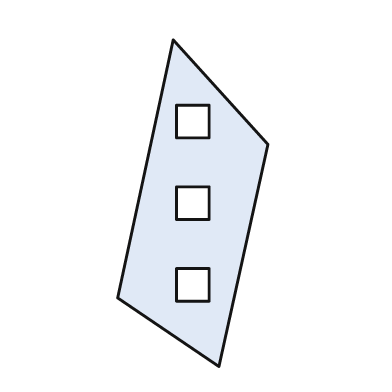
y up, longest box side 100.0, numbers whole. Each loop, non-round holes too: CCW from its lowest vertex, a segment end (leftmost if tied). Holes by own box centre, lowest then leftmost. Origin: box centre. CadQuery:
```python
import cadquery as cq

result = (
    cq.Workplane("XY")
    .moveTo(8.0, -50.0)
    .lineTo(23.0, 18.0)
    .lineTo(-6.0, 50.0)
    .lineTo(-23.0, -29.0)
    .close()
    .moveTo(-5.0, -30.0)
    .lineTo(5.0, -30.0)
    .lineTo(5.0, -20.0)
    .lineTo(-5.0, -20.0)
    .close()
    .moveTo(-5.0, -5.0)
    .lineTo(5.0, -5.0)
    .lineTo(5.0, 5.0)
    .lineTo(-5.0, 5.0)
    .close()
    .moveTo(-5.0, 20.0)
    .lineTo(5.0, 20.0)
    .lineTo(5.0, 30.0)
    .lineTo(-5.0, 30.0)
    .close()
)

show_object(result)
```